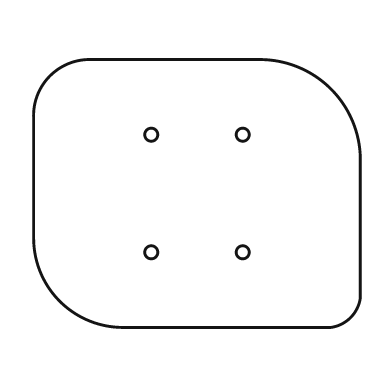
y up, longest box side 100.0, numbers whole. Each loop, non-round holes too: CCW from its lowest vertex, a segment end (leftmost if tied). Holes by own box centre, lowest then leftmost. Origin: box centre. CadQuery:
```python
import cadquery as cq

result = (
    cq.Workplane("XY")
    .moveTo(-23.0, -41.0)
    .lineTo(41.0, -41.0)
    .threePointArc((47.0, -38.0), (50.0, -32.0))
    .lineTo(50.0, 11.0)
    .threePointArc((41.0, 32.0), (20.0, 41.0))
    .lineTo(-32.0, 41.0)
    .threePointArc((-45.0, 36.0), (-50.0, 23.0))
    .lineTo(-50.0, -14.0)
    .threePointArc((-42.0, -33.0), (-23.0, -41.0))
    .close()
    .moveTo(-14.0, -18.0)
    .circle(2.0)
    .moveTo(14.0, -18.0)
    .circle(2.0)
    .moveTo(-14.0, 18.0)
    .circle(2.0)
    .moveTo(14.0, 18.0)
    .circle(2.0)
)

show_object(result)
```